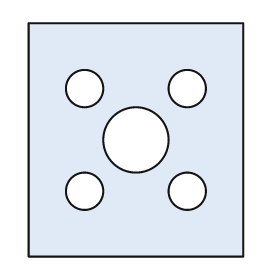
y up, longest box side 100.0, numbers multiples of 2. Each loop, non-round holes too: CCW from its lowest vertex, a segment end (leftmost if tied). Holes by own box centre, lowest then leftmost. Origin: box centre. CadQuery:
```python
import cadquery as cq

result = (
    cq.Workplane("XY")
    .moveTo(-46.0, -50.0)
    .lineTo(46.0, -50.0)
    .lineTo(46.0, 50.0)
    .lineTo(-46.0, 50.0)
    .close()
    .moveTo(-22.0, -22.0)
    .circle(8.0)
    .moveTo(22.0, -22.0)
    .circle(8.0)
    .moveTo(0.0, 0.0)
    .circle(14.0)
    .moveTo(-22.0, 22.0)
    .circle(8.0)
    .moveTo(22.0, 22.0)
    .circle(8.0)
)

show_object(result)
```